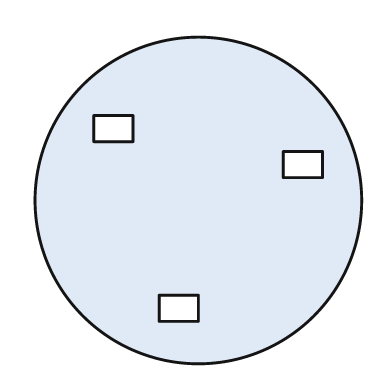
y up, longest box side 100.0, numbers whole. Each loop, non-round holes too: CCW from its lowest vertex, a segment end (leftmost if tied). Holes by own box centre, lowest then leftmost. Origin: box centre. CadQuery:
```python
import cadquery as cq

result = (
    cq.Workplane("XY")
    .moveTo(0.0, 0.0)
    .circle(50.0)
    .moveTo(-12.0, -37.0)
    .lineTo(0.0, -37.0)
    .lineTo(0.0, -29.0)
    .lineTo(-12.0, -29.0)
    .close()
    .moveTo(26.0, 7.0)
    .lineTo(38.0, 7.0)
    .lineTo(38.0, 15.0)
    .lineTo(26.0, 15.0)
    .close()
    .moveTo(-32.0, 18.0)
    .lineTo(-20.0, 18.0)
    .lineTo(-20.0, 26.0)
    .lineTo(-32.0, 26.0)
    .close()
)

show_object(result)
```